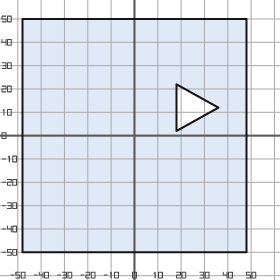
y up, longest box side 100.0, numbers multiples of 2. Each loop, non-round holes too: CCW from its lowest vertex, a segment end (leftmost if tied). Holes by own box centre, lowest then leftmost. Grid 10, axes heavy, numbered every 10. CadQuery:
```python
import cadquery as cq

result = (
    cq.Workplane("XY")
    .moveTo(-48.0, -50.0)
    .lineTo(48.0, -50.0)
    .lineTo(48.0, 50.0)
    .lineTo(-48.0, 50.0)
    .close()
    .moveTo(18.0, 2.0)
    .lineTo(36.0, 12.0)
    .lineTo(18.0, 22.0)
    .close()
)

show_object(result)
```